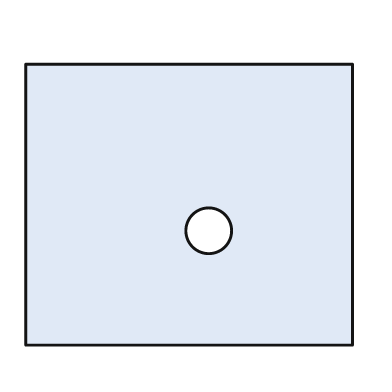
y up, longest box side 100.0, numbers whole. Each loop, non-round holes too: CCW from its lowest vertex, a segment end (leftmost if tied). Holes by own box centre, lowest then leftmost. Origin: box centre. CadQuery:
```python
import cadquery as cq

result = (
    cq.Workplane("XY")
    .moveTo(-50.0, -43.0)
    .lineTo(50.0, -43.0)
    .lineTo(50.0, 43.0)
    .lineTo(-50.0, 43.0)
    .close()
    .moveTo(6.0, -8.0)
    .circle(7.0)
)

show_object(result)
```